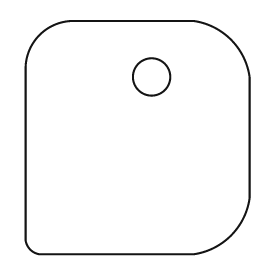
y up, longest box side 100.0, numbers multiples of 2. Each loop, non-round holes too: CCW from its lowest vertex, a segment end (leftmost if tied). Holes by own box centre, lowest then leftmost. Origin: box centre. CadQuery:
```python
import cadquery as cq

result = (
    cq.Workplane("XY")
    .moveTo(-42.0, -50.0)
    .lineTo(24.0, -50.0)
    .threePointArc((40.0, -42.0), (48.0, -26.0))
    .lineTo(48.0, 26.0)
    .threePointArc((40.0, 42.0), (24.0, 50.0))
    .lineTo(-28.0, 50.0)
    .threePointArc((-42.0, 44.0), (-48.0, 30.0))
    .lineTo(-48.0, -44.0)
    .threePointArc((-46.0, -48.0), (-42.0, -50.0))
    .close()
    .moveTo(6.0, 26.0)
    .circle(8.0)
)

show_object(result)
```